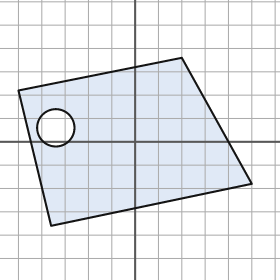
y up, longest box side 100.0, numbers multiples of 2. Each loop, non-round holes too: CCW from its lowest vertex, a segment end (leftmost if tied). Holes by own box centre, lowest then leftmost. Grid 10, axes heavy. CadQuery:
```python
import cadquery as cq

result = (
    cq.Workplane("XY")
    .moveTo(-36.0, -36.0)
    .lineTo(50.0, -18.0)
    .lineTo(20.0, 36.0)
    .lineTo(-50.0, 22.0)
    .close()
    .moveTo(-34.0, 6.0)
    .circle(8.0)
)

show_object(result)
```